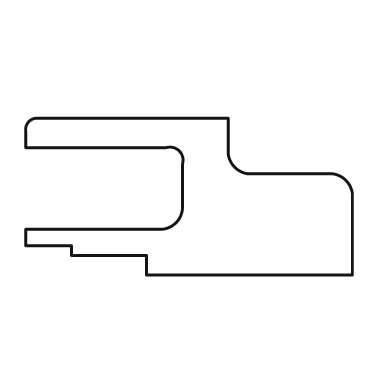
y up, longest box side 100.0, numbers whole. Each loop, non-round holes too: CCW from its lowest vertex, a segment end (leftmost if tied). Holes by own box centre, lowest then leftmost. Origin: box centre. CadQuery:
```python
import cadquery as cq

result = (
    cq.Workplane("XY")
    .moveTo(-13.0, -24.0)
    .lineTo(50.0, -24.0)
    .lineTo(50.0, 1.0)
    .threePointArc((48.0, 5.0), (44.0, 7.0))
    .lineTo(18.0, 7.0)
    .threePointArc((14.0, 9.0), (12.0, 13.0))
    .lineTo(12.0, 24.0)
    .lineTo(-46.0, 24.0)
    .threePointArc((-49.0, 23.0), (-50.0, 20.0))
    .lineTo(-50.0, 15.0)
    .lineTo(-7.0, 15.0)
    .threePointArc((-3.0, 14.0), (-2.0, 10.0))
    .lineTo(-2.0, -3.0)
    .threePointArc((-4.0, -8.0), (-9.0, -10.0))
    .lineTo(-50.0, -10.0)
    .lineTo(-50.0, -15.0)
    .lineTo(-36.0, -15.0)
    .lineTo(-36.0, -18.0)
    .lineTo(-13.0, -18.0)
    .close()
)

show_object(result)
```